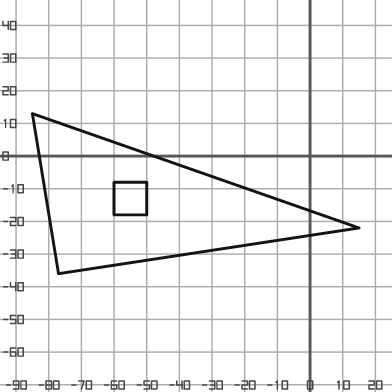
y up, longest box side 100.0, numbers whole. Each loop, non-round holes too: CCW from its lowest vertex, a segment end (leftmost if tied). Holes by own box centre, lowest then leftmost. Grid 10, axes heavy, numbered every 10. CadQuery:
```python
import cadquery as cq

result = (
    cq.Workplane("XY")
    .moveTo(-77.0, -36.0)
    .lineTo(15.0, -22.0)
    .lineTo(-85.0, 13.0)
    .close()
    .moveTo(-60.0, -18.0)
    .lineTo(-50.0, -18.0)
    .lineTo(-50.0, -8.0)
    .lineTo(-60.0, -8.0)
    .close()
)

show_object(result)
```